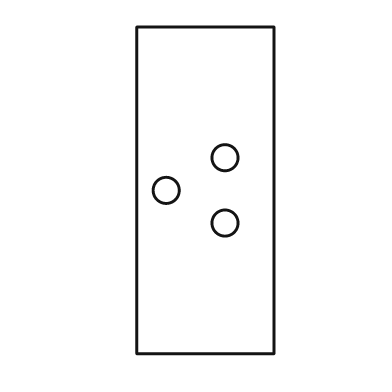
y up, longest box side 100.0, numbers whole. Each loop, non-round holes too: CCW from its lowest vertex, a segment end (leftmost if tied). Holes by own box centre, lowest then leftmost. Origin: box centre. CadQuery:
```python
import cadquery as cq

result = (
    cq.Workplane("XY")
    .moveTo(-21.0, -50.0)
    .lineTo(21.0, -50.0)
    .lineTo(21.0, 50.0)
    .lineTo(-21.0, 50.0)
    .close()
    .moveTo(6.0, -10.0)
    .circle(4.0)
    .moveTo(-12.0, 0.0)
    .circle(4.0)
    .moveTo(6.0, 10.0)
    .circle(4.0)
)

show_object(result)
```